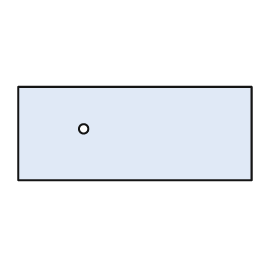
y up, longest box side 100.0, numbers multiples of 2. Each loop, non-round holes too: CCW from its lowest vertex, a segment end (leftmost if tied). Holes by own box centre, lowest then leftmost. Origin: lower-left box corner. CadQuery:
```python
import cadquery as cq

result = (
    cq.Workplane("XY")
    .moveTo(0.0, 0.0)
    .lineTo(100.0, 0.0)
    .lineTo(100.0, 40.0)
    .lineTo(0.0, 40.0)
    .close()
    .moveTo(28.0, 22.0)
    .circle(2.0)
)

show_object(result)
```